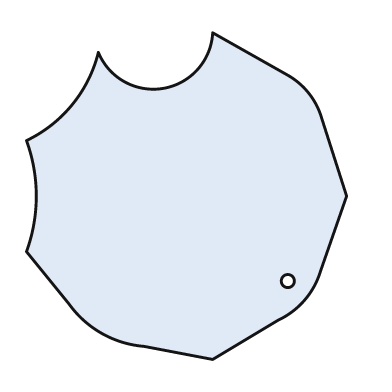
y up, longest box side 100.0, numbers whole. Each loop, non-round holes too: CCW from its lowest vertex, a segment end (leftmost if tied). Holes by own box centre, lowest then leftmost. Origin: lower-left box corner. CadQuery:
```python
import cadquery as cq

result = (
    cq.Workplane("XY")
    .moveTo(57.0, 0.0)
    .lineTo(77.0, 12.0)
    .threePointArc((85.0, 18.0), (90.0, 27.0))
    .lineTo(98.0, 50.0)
    .lineTo(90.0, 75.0)
    .threePointArc((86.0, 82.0), (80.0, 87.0))
    .lineTo(57.0, 100.0)
    .threePointArc((42.0, 83.0), (22.0, 94.0))
    .threePointArc((14.0, 78.0), (0.0, 67.0))
    .threePointArc((3.0, 50.0), (0.0, 33.0))
    .lineTo(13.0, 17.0)
    .threePointArc((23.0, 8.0), (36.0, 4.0))
    .close()
    .moveTo(80.0, 24.0)
    .circle(2.0)
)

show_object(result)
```